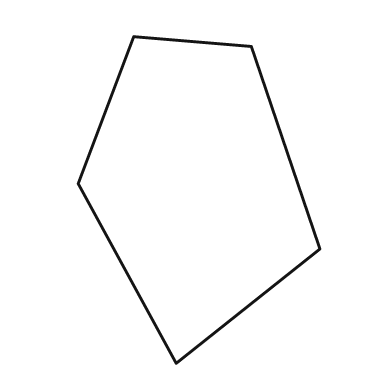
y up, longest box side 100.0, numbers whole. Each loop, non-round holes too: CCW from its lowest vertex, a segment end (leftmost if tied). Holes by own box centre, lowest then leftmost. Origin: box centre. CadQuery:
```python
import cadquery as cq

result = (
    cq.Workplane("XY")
    .moveTo(-7.0, -50.0)
    .lineTo(37.0, -15.0)
    .lineTo(16.0, 47.0)
    .lineTo(-20.0, 50.0)
    .lineTo(-37.0, 5.0)
    .close()
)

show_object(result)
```